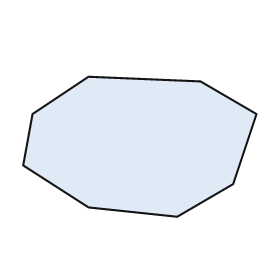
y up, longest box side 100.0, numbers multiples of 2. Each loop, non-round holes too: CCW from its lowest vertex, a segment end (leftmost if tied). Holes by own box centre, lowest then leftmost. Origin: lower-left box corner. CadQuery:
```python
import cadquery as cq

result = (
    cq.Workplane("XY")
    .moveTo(66.0, 0.0)
    .lineTo(90.0, 14.0)
    .lineTo(100.0, 44.0)
    .lineTo(76.0, 58.0)
    .lineTo(28.0, 60.0)
    .lineTo(4.0, 44.0)
    .lineTo(0.0, 22.0)
    .lineTo(28.0, 4.0)
    .close()
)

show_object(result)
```